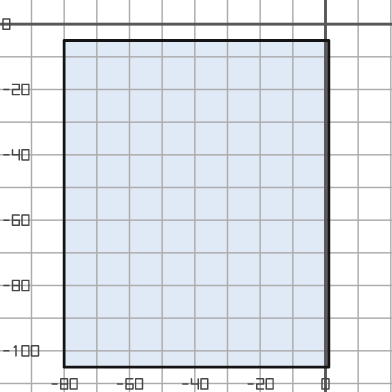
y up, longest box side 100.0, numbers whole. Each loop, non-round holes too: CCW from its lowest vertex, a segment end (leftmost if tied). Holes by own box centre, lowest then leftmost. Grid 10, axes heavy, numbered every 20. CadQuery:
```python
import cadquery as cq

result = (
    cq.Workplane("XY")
    .moveTo(-80.0, -105.0)
    .lineTo(1.0, -105.0)
    .lineTo(1.0, -5.0)
    .lineTo(-80.0, -5.0)
    .close()
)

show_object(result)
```